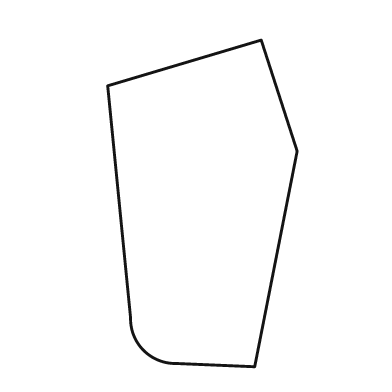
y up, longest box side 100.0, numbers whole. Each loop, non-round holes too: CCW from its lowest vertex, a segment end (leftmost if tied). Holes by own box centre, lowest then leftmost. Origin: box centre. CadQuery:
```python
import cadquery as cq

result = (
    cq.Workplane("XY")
    .moveTo(16.0, -50.0)
    .lineTo(29.0, 16.0)
    .lineTo(18.0, 50.0)
    .lineTo(-29.0, 36.0)
    .lineTo(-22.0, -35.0)
    .threePointArc((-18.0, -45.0), (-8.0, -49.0))
    .close()
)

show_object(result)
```